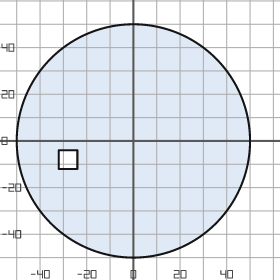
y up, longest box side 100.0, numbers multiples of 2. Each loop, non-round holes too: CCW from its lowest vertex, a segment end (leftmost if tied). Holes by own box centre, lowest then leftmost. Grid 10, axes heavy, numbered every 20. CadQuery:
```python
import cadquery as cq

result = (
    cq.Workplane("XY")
    .moveTo(0.0, 0.0)
    .circle(50.0)
    .moveTo(-32.0, -12.0)
    .lineTo(-24.0, -12.0)
    .lineTo(-24.0, -4.0)
    .lineTo(-32.0, -4.0)
    .close()
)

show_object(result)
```